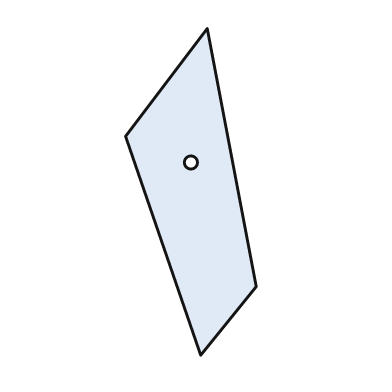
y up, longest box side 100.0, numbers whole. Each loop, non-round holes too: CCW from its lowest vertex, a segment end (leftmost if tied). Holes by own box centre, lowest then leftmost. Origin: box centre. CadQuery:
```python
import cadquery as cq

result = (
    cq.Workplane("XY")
    .moveTo(3.0, -50.0)
    .lineTo(20.0, -29.0)
    .lineTo(5.0, 50.0)
    .lineTo(-20.0, 17.0)
    .close()
    .moveTo(0.0, 9.0)
    .circle(2.0)
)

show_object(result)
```